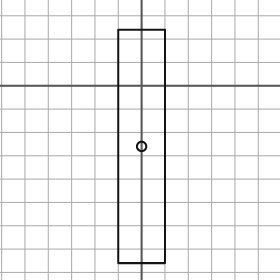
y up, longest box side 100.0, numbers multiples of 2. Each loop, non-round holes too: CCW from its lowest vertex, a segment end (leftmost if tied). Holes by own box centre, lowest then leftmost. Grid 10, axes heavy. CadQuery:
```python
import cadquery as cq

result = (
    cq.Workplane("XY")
    .moveTo(-10.0, -76.0)
    .lineTo(10.0, -76.0)
    .lineTo(10.0, 24.0)
    .lineTo(-10.0, 24.0)
    .close()
    .moveTo(0.0, -26.0)
    .circle(2.0)
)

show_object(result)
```